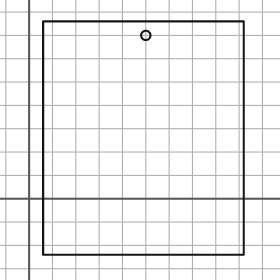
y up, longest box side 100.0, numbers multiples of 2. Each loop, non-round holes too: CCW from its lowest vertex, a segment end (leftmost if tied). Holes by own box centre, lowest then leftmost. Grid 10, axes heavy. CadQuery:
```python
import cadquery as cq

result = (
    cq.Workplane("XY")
    .moveTo(6.0, -24.0)
    .lineTo(92.0, -24.0)
    .lineTo(92.0, 76.0)
    .lineTo(6.0, 76.0)
    .close()
    .moveTo(50.0, 70.0)
    .circle(2.0)
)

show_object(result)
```